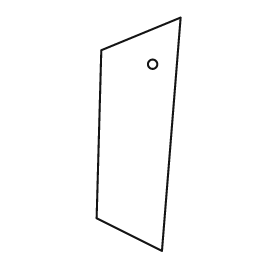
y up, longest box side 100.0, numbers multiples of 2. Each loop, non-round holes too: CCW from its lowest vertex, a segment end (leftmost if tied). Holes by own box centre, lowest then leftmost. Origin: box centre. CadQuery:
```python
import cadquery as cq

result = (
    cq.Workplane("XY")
    .moveTo(10.0, -50.0)
    .lineTo(18.0, 50.0)
    .lineTo(-16.0, 36.0)
    .lineTo(-18.0, -36.0)
    .close()
    .moveTo(6.0, 30.0)
    .circle(2.0)
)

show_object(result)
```